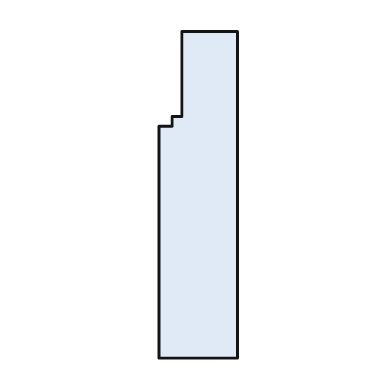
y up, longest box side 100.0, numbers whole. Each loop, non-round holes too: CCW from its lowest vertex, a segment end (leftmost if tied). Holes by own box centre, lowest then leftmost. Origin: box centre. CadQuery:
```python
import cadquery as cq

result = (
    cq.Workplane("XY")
    .moveTo(-12.0, -50.0)
    .lineTo(12.0, -50.0)
    .lineTo(12.0, 50.0)
    .lineTo(-5.0, 50.0)
    .lineTo(-5.0, 24.0)
    .lineTo(-8.0, 24.0)
    .lineTo(-8.0, 21.0)
    .lineTo(-12.0, 21.0)
    .close()
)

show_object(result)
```